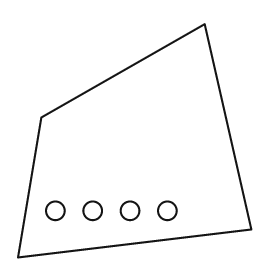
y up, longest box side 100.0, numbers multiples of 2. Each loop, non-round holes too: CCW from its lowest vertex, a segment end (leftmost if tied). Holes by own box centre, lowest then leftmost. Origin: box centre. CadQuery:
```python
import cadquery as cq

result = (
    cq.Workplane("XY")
    .moveTo(-50.0, -50.0)
    .lineTo(50.0, -38.0)
    .lineTo(30.0, 50.0)
    .lineTo(-40.0, 10.0)
    .close()
    .moveTo(-34.0, -30.0)
    .circle(4.0)
    .moveTo(-18.0, -30.0)
    .circle(4.0)
    .moveTo(-2.0, -30.0)
    .circle(4.0)
    .moveTo(14.0, -30.0)
    .circle(4.0)
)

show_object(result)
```